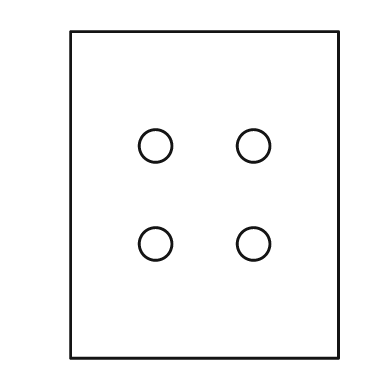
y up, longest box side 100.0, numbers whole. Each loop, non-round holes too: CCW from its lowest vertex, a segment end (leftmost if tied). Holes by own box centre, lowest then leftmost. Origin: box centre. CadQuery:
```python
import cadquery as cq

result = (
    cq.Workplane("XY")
    .moveTo(-41.0, -50.0)
    .lineTo(41.0, -50.0)
    .lineTo(41.0, 50.0)
    .lineTo(-41.0, 50.0)
    .close()
    .moveTo(-15.0, -15.0)
    .circle(5.0)
    .moveTo(15.0, -15.0)
    .circle(5.0)
    .moveTo(-15.0, 15.0)
    .circle(5.0)
    .moveTo(15.0, 15.0)
    .circle(5.0)
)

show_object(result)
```